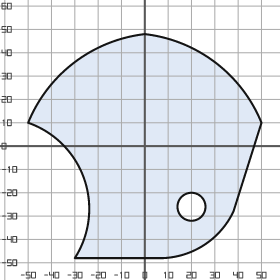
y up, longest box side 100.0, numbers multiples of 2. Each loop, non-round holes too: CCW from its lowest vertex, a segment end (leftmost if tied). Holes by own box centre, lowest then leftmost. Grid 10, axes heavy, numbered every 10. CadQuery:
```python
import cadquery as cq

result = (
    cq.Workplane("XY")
    .moveTo(-30.0, -48.0)
    .lineTo(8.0, -48.0)
    .threePointArc((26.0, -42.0), (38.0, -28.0))
    .lineTo(50.0, 10.0)
    .threePointArc((30.0, 36.0), (0.0, 48.0))
    .threePointArc((-30.0, 36.0), (-50.0, 10.0))
    .threePointArc((-26.0, -14.0), (-30.0, -48.0))
    .close()
    .moveTo(20.0, -26.0)
    .circle(6.0)
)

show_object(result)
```